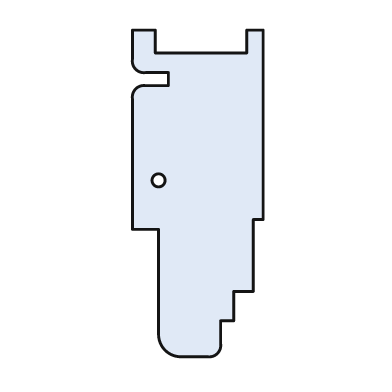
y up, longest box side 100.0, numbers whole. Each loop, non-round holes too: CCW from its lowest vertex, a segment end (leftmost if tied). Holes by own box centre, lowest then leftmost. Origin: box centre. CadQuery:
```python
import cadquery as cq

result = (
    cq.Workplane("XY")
    .moveTo(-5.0, -50.0)
    .lineTo(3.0, -50.0)
    .threePointArc((6.0, -49.0), (7.0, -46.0))
    .lineTo(7.0, -39.0)
    .lineTo(11.0, -39.0)
    .lineTo(11.0, -30.0)
    .lineTo(17.0, -30.0)
    .lineTo(17.0, -8.0)
    .lineTo(20.0, -8.0)
    .lineTo(20.0, 50.0)
    .lineTo(15.0, 50.0)
    .lineTo(15.0, 43.0)
    .lineTo(-13.0, 43.0)
    .lineTo(-13.0, 50.0)
    .lineTo(-20.0, 50.0)
    .lineTo(-20.0, 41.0)
    .threePointArc((-19.0, 38.0), (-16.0, 37.0))
    .lineTo(-9.0, 37.0)
    .lineTo(-9.0, 33.0)
    .lineTo(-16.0, 33.0)
    .threePointArc((-19.0, 32.0), (-20.0, 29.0))
    .lineTo(-20.0, -11.0)
    .lineTo(-12.0, -11.0)
    .lineTo(-12.0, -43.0)
    .threePointArc((-10.0, -48.0), (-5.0, -50.0))
    .close()
    .moveTo(-12.0, 4.0)
    .circle(2.0)
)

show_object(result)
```